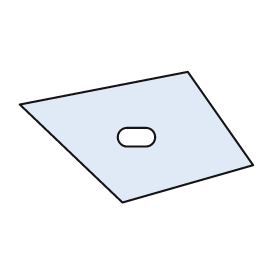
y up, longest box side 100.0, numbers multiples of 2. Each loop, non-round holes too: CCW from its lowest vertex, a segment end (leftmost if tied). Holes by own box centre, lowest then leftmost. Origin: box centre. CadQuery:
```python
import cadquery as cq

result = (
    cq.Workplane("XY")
    .moveTo(-6.0, -28.0)
    .lineTo(50.0, -12.0)
    .lineTo(22.0, 28.0)
    .lineTo(-50.0, 14.0)
    .close()
    .moveTo(-4.0, -4.0)
    .lineTo(4.0, -4.0)
    .threePointArc((8.0, 0.0), (4.0, 4.0))
    .lineTo(-4.0, 4.0)
    .threePointArc((-8.0, 0.0), (-4.0, -4.0))
    .close()
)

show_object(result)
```